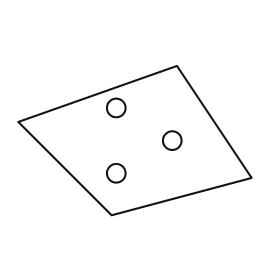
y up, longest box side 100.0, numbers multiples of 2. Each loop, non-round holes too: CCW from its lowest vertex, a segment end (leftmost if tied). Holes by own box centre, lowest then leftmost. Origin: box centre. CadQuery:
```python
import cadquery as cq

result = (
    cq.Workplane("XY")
    .moveTo(-10.0, -32.0)
    .lineTo(50.0, -16.0)
    .lineTo(18.0, 32.0)
    .lineTo(-50.0, 8.0)
    .close()
    .moveTo(-8.0, -14.0)
    .circle(4.0)
    .moveTo(16.0, 0.0)
    .circle(4.0)
    .moveTo(-8.0, 14.0)
    .circle(4.0)
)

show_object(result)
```